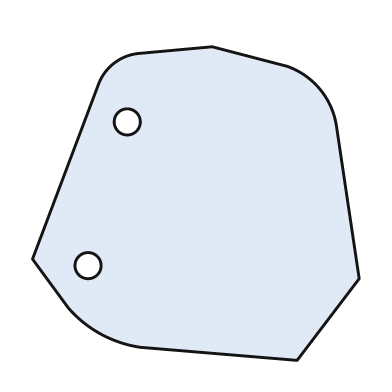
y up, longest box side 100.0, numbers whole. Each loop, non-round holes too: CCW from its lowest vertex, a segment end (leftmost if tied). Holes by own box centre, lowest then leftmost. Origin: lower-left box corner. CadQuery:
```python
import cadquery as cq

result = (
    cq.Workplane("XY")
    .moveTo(81.0, 0.0)
    .lineTo(100.0, 25.0)
    .lineTo(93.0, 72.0)
    .threePointArc((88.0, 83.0), (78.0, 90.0))
    .lineTo(55.0, 96.0)
    .lineTo(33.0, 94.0)
    .threePointArc((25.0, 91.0), (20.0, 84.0))
    .lineTo(0.0, 31.0)
    .lineTo(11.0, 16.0)
    .threePointArc((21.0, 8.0), (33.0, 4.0))
    .close()
    .moveTo(17.0, 29.0)
    .circle(4.0)
    .moveTo(29.0, 73.0)
    .circle(4.0)
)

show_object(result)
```